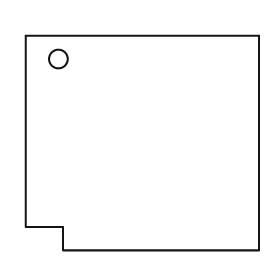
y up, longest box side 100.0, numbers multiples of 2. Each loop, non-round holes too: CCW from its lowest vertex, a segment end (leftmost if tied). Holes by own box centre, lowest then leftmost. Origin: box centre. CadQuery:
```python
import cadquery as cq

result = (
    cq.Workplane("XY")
    .moveTo(-34.0, -46.0)
    .lineTo(50.0, -46.0)
    .lineTo(50.0, 46.0)
    .lineTo(-50.0, 46.0)
    .lineTo(-50.0, -36.0)
    .lineTo(-34.0, -36.0)
    .close()
    .moveTo(-36.0, 36.0)
    .circle(4.0)
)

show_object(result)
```